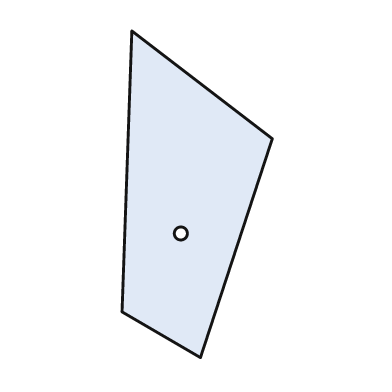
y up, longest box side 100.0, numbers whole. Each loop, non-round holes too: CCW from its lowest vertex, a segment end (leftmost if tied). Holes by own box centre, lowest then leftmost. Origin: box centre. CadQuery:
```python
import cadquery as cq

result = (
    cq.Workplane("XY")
    .moveTo(1.0, -50.0)
    .lineTo(23.0, 17.0)
    .lineTo(-20.0, 50.0)
    .lineTo(-23.0, -36.0)
    .close()
    .moveTo(-5.0, -12.0)
    .circle(2.0)
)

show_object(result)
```